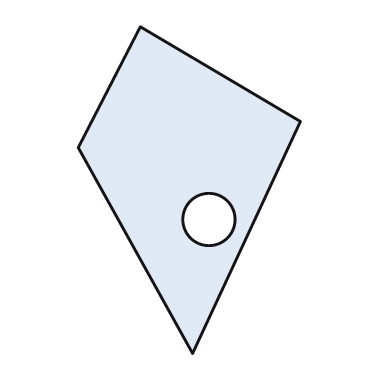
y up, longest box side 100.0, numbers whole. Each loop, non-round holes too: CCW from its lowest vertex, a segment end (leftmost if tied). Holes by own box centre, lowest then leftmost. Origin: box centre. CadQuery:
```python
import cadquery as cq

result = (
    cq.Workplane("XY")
    .moveTo(1.0, -50.0)
    .lineTo(34.0, 21.0)
    .lineTo(-15.0, 50.0)
    .lineTo(-34.0, 13.0)
    .close()
    .moveTo(6.0, -9.0)
    .circle(8.0)
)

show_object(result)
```